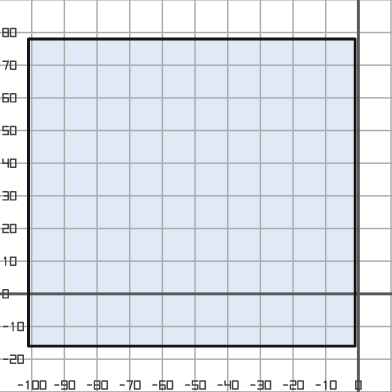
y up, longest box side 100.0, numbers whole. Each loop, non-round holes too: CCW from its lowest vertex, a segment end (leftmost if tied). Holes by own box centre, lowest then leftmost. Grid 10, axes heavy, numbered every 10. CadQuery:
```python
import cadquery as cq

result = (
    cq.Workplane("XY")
    .moveTo(-101.0, -16.0)
    .lineTo(-1.0, -16.0)
    .lineTo(-1.0, 78.0)
    .lineTo(-101.0, 78.0)
    .close()
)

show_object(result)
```